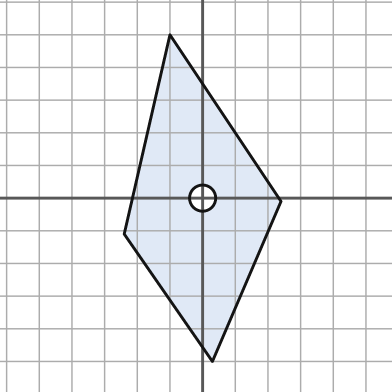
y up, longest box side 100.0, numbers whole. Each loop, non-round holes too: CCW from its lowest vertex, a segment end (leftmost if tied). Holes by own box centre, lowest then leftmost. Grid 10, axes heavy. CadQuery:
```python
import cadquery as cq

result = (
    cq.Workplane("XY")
    .moveTo(3.0, -50.0)
    .lineTo(24.0, -1.0)
    .lineTo(-10.0, 50.0)
    .lineTo(-24.0, -11.0)
    .close()
    .moveTo(0.0, 0.0)
    .circle(4.0)
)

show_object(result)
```